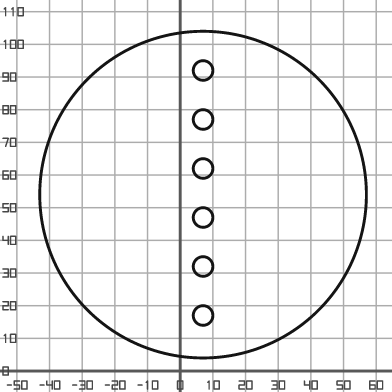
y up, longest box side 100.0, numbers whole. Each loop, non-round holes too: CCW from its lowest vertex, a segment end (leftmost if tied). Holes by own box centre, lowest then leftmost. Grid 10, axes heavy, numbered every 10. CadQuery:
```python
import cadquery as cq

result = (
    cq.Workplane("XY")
    .moveTo(7.0, 54.0)
    .circle(50.0)
    .moveTo(7.0, 17.0)
    .circle(3.0)
    .moveTo(7.0, 32.0)
    .circle(3.0)
    .moveTo(7.0, 47.0)
    .circle(3.0)
    .moveTo(7.0, 62.0)
    .circle(3.0)
    .moveTo(7.0, 77.0)
    .circle(3.0)
    .moveTo(7.0, 92.0)
    .circle(3.0)
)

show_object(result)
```